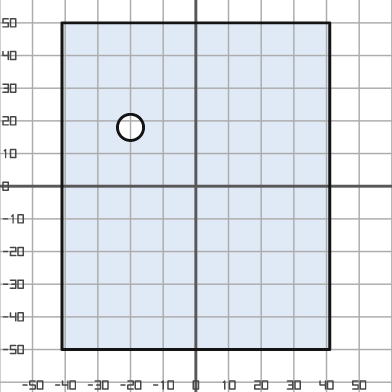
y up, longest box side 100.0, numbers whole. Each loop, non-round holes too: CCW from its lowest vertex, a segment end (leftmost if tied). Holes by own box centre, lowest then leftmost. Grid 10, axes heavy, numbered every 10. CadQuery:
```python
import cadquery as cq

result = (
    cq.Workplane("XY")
    .moveTo(-41.0, -50.0)
    .lineTo(41.0, -50.0)
    .lineTo(41.0, 50.0)
    .lineTo(-41.0, 50.0)
    .close()
    .moveTo(-20.0, 18.0)
    .circle(4.0)
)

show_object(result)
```